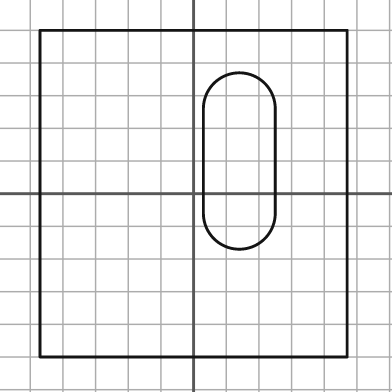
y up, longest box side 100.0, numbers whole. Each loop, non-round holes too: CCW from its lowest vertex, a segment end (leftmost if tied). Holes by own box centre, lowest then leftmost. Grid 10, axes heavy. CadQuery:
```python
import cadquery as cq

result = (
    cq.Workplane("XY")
    .moveTo(-47.0, -50.0)
    .lineTo(47.0, -50.0)
    .lineTo(47.0, 50.0)
    .lineTo(-47.0, 50.0)
    .close()
    .moveTo(3.0, -6.0)
    .threePointArc((14.0, -17.0), (25.0, -6.0))
    .lineTo(25.0, 26.0)
    .threePointArc((14.0, 37.0), (3.0, 26.0))
    .close()
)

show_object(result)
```